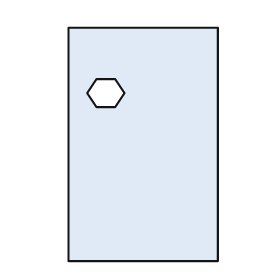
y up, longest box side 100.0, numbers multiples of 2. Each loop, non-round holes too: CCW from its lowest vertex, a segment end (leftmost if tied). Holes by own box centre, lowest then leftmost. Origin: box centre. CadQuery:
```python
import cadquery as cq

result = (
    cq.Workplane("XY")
    .moveTo(-32.0, -50.0)
    .lineTo(32.0, -50.0)
    .lineTo(32.0, 50.0)
    .lineTo(-32.0, 50.0)
    .close()
    .moveTo(-20.0, 16.0)
    .lineTo(-12.0, 16.0)
    .lineTo(-8.0, 22.0)
    .lineTo(-12.0, 28.0)
    .lineTo(-20.0, 28.0)
    .lineTo(-24.0, 22.0)
    .close()
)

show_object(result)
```